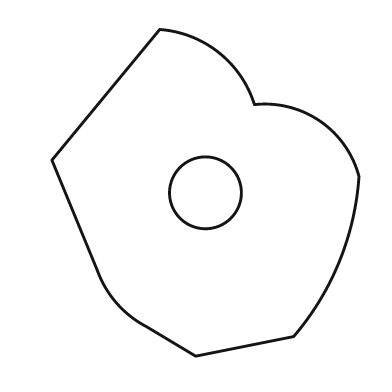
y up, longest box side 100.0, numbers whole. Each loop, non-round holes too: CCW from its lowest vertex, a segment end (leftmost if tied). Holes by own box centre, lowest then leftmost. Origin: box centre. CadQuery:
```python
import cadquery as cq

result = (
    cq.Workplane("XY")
    .moveTo(-3.0, -50.0)
    .lineTo(27.0, -44.0)
    .threePointArc((41.0, -21.0), (47.0, 5.0))
    .threePointArc((35.0, 22.0), (15.0, 27.0))
    .threePointArc((4.0, 43.0), (-14.0, 50.0))
    .lineTo(-47.0, 10.0)
    .lineTo(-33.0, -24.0)
    .threePointArc((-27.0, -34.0), (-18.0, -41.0))
    .close()
    .moveTo(0.0, 0.0)
    .circle(11.0)
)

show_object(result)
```